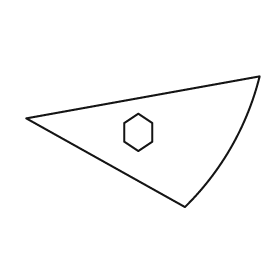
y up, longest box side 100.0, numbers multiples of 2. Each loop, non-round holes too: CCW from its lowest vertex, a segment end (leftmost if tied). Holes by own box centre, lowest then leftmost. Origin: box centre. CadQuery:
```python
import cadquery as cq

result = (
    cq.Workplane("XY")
    .moveTo(18.0, -28.0)
    .threePointArc((38.0, -2.0), (50.0, 28.0))
    .lineTo(-50.0, 10.0)
    .close()
    .moveTo(-2.0, -4.0)
    .lineTo(4.0, 0.0)
    .lineTo(4.0, 8.0)
    .lineTo(-2.0, 12.0)
    .lineTo(-8.0, 8.0)
    .lineTo(-8.0, 0.0)
    .close()
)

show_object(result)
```